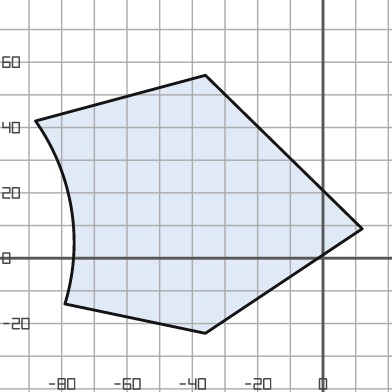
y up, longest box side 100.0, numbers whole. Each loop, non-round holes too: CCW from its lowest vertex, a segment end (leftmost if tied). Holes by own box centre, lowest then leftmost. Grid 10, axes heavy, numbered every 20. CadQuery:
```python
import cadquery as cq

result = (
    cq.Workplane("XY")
    .moveTo(-36.0, -23.0)
    .lineTo(12.0, 9.0)
    .lineTo(-36.0, 56.0)
    .lineTo(-88.0, 42.0)
    .threePointArc((-77.0, 15.0), (-79.0, -14.0))
    .close()
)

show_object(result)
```